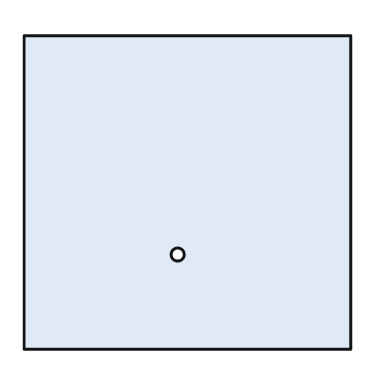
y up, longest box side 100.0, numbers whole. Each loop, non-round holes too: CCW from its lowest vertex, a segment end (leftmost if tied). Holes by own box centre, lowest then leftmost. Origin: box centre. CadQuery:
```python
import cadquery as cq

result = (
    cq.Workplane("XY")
    .moveTo(-50.0, -48.0)
    .lineTo(50.0, -48.0)
    .lineTo(50.0, 48.0)
    .lineTo(-50.0, 48.0)
    .close()
    .moveTo(-3.0, -19.0)
    .circle(2.0)
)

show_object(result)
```